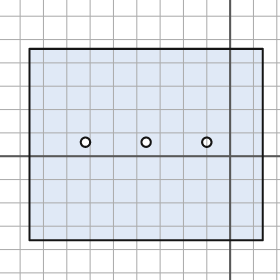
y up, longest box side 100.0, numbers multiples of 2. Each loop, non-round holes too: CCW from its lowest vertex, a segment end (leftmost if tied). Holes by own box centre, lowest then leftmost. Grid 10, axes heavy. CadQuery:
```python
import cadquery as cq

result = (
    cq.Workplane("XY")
    .moveTo(-86.0, -36.0)
    .lineTo(14.0, -36.0)
    .lineTo(14.0, 46.0)
    .lineTo(-86.0, 46.0)
    .close()
    .moveTo(-62.0, 6.0)
    .circle(2.0)
    .moveTo(-36.0, 6.0)
    .circle(2.0)
    .moveTo(-10.0, 6.0)
    .circle(2.0)
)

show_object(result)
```